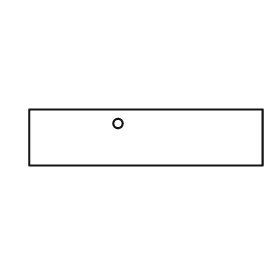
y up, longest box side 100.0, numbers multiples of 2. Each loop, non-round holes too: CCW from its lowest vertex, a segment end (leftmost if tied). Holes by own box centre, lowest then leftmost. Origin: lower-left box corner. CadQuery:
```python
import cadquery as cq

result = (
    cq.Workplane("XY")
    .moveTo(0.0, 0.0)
    .lineTo(100.0, 0.0)
    .lineTo(100.0, 24.0)
    .lineTo(0.0, 24.0)
    .close()
    .moveTo(38.0, 18.0)
    .circle(2.0)
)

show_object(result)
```